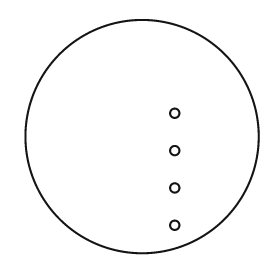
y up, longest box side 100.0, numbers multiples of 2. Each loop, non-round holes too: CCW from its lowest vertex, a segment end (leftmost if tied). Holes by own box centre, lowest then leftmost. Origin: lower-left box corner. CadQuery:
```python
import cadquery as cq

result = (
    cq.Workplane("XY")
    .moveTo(50.0, 50.0)
    .circle(50.0)
    .moveTo(64.0, 12.0)
    .circle(2.0)
    .moveTo(64.0, 28.0)
    .circle(2.0)
    .moveTo(64.0, 44.0)
    .circle(2.0)
    .moveTo(64.0, 60.0)
    .circle(2.0)
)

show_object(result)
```